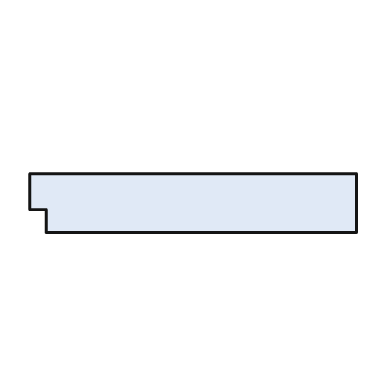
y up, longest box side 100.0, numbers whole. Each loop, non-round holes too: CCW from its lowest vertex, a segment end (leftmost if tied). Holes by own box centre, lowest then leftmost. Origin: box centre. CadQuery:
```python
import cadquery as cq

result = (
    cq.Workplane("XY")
    .moveTo(-45.0, -9.0)
    .lineTo(50.0, -9.0)
    .lineTo(50.0, 9.0)
    .lineTo(-50.0, 9.0)
    .lineTo(-50.0, -2.0)
    .lineTo(-45.0, -2.0)
    .close()
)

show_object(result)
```